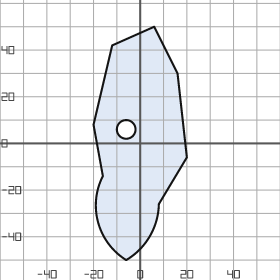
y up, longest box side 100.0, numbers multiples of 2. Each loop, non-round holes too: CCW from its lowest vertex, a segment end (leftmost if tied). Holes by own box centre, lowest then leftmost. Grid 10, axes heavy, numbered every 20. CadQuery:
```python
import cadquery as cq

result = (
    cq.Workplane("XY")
    .moveTo(-6.0, -50.0)
    .threePointArc((4.0, -40.0), (8.0, -26.0))
    .lineTo(20.0, -6.0)
    .lineTo(16.0, 30.0)
    .lineTo(6.0, 50.0)
    .lineTo(-12.0, 42.0)
    .lineTo(-20.0, 8.0)
    .lineTo(-16.0, -14.0)
    .threePointArc((-18.0, -34.0), (-6.0, -50.0))
    .close()
    .moveTo(-6.0, 6.0)
    .circle(4.0)
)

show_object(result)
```